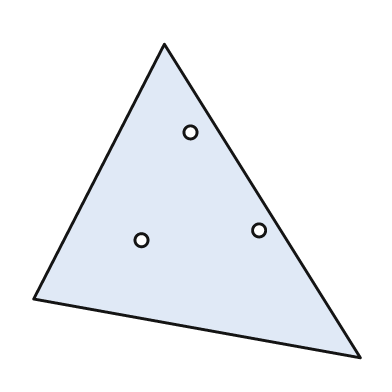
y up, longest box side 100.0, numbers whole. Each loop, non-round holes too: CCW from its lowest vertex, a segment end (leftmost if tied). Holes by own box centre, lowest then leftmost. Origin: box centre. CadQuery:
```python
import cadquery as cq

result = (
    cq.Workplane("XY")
    .moveTo(50.0, -48.0)
    .lineTo(-10.0, 48.0)
    .lineTo(-50.0, -30.0)
    .close()
    .moveTo(-17.0, -12.0)
    .circle(2.0)
    .moveTo(19.0, -9.0)
    .circle(2.0)
    .moveTo(-2.0, 21.0)
    .circle(2.0)
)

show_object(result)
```